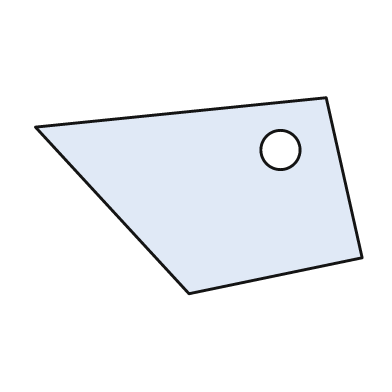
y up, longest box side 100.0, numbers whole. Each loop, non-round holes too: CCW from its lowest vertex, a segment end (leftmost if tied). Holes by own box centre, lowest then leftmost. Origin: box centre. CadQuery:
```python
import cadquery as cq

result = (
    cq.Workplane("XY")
    .moveTo(-3.0, -30.0)
    .lineTo(50.0, -19.0)
    .lineTo(39.0, 30.0)
    .lineTo(-50.0, 21.0)
    .close()
    .moveTo(25.0, 14.0)
    .circle(6.0)
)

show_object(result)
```